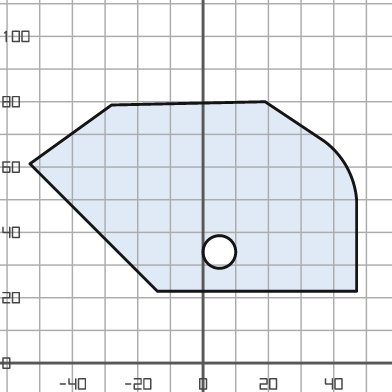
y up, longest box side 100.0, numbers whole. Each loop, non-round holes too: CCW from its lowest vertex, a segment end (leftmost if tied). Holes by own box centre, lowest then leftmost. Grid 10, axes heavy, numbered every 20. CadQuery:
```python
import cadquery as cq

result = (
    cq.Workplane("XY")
    .moveTo(-14.0, 22.0)
    .lineTo(47.0, 22.0)
    .lineTo(47.0, 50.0)
    .threePointArc((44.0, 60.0), (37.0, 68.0))
    .lineTo(19.0, 80.0)
    .lineTo(-28.0, 79.0)
    .lineTo(-53.0, 61.0)
    .close()
    .moveTo(5.0, 34.0)
    .circle(5.0)
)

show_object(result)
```